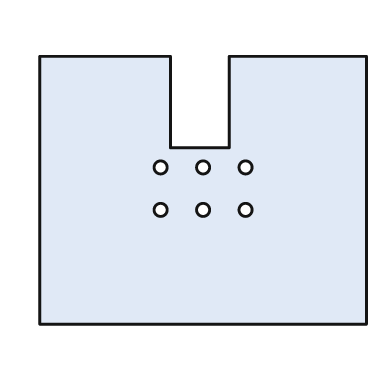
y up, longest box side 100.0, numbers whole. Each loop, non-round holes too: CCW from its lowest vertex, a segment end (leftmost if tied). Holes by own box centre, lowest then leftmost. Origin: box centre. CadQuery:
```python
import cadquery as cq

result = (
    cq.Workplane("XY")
    .moveTo(-50.0, -41.0)
    .lineTo(50.0, -41.0)
    .lineTo(50.0, 41.0)
    .lineTo(8.0, 41.0)
    .lineTo(8.0, 13.0)
    .lineTo(-10.0, 13.0)
    .lineTo(-10.0, 41.0)
    .lineTo(-50.0, 41.0)
    .close()
    .moveTo(-13.0, -6.0)
    .circle(2.0)
    .moveTo(0.0, -6.0)
    .circle(2.0)
    .moveTo(13.0, -6.0)
    .circle(2.0)
    .moveTo(-13.0, 7.0)
    .circle(2.0)
    .moveTo(0.0, 7.0)
    .circle(2.0)
    .moveTo(13.0, 7.0)
    .circle(2.0)
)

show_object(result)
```